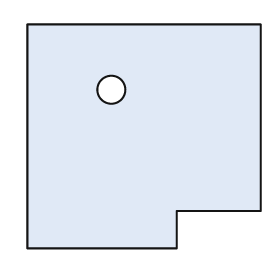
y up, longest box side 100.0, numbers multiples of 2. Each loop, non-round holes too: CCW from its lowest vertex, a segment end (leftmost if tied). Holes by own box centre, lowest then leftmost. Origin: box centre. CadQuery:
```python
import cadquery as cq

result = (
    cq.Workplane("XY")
    .moveTo(-50.0, -48.0)
    .lineTo(14.0, -48.0)
    .lineTo(14.0, -32.0)
    .lineTo(50.0, -32.0)
    .lineTo(50.0, 48.0)
    .lineTo(-50.0, 48.0)
    .close()
    .moveTo(-14.0, 20.0)
    .circle(6.0)
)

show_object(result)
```